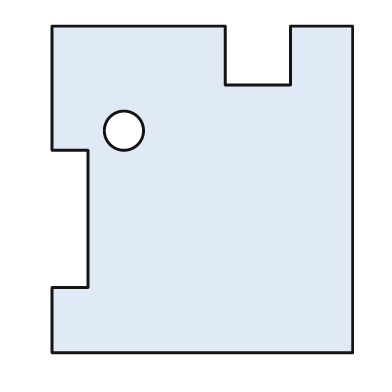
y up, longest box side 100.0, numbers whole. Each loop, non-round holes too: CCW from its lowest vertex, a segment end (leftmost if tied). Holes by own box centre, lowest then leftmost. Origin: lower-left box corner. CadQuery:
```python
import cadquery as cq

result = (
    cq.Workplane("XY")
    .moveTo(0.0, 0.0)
    .lineTo(92.0, 0.0)
    .lineTo(92.0, 100.0)
    .lineTo(73.0, 100.0)
    .lineTo(73.0, 82.0)
    .lineTo(53.0, 82.0)
    .lineTo(53.0, 100.0)
    .lineTo(0.0, 100.0)
    .lineTo(0.0, 62.0)
    .lineTo(11.0, 62.0)
    .lineTo(11.0, 20.0)
    .lineTo(0.0, 20.0)
    .close()
    .moveTo(22.0, 68.0)
    .circle(6.0)
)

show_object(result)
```